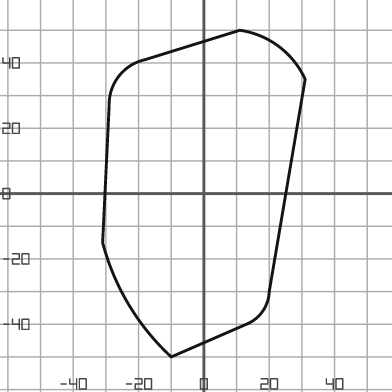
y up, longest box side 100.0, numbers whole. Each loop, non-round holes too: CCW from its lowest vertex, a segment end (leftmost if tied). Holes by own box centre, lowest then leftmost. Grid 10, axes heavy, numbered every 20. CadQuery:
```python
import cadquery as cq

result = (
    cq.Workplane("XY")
    .moveTo(-10.0, -50.0)
    .lineTo(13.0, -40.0)
    .threePointArc((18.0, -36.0), (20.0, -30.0))
    .lineTo(31.0, 35.0)
    .threePointArc((23.0, 45.0), (11.0, 50.0))
    .lineTo(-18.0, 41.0)
    .threePointArc((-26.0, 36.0), (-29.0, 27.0))
    .lineTo(-31.0, -15.0)
    .threePointArc((-23.0, -34.0), (-10.0, -50.0))
    .close()
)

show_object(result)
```